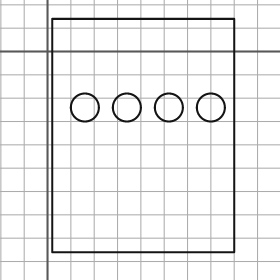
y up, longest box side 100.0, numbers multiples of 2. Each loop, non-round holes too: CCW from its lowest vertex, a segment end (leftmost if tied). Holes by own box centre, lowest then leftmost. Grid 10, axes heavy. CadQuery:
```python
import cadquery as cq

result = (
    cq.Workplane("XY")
    .moveTo(2.0, -86.0)
    .lineTo(80.0, -86.0)
    .lineTo(80.0, 14.0)
    .lineTo(2.0, 14.0)
    .close()
    .moveTo(16.0, -24.0)
    .circle(6.0)
    .moveTo(34.0, -24.0)
    .circle(6.0)
    .moveTo(52.0, -24.0)
    .circle(6.0)
    .moveTo(70.0, -24.0)
    .circle(6.0)
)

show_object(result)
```